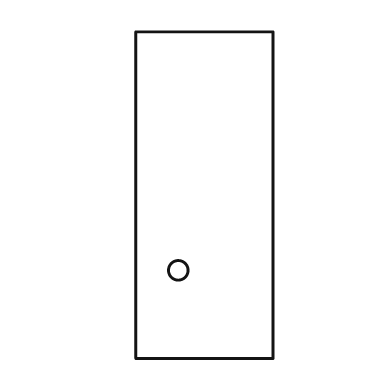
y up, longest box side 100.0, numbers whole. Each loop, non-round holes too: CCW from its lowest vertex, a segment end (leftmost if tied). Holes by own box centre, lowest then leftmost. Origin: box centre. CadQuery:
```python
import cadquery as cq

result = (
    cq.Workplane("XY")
    .moveTo(-21.0, -50.0)
    .lineTo(21.0, -50.0)
    .lineTo(21.0, 50.0)
    .lineTo(-21.0, 50.0)
    .close()
    .moveTo(-8.0, -23.0)
    .circle(3.0)
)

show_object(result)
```